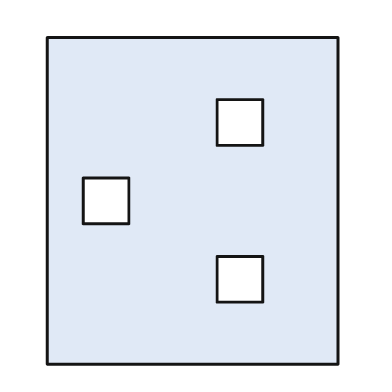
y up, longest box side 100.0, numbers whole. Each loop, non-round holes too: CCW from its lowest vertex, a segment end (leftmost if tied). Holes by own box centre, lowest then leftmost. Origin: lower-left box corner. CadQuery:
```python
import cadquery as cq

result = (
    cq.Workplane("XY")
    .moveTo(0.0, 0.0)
    .lineTo(89.0, 0.0)
    .lineTo(89.0, 100.0)
    .lineTo(0.0, 100.0)
    .close()
    .moveTo(52.0, 19.0)
    .lineTo(66.0, 19.0)
    .lineTo(66.0, 33.0)
    .lineTo(52.0, 33.0)
    .close()
    .moveTo(11.0, 43.0)
    .lineTo(25.0, 43.0)
    .lineTo(25.0, 57.0)
    .lineTo(11.0, 57.0)
    .close()
    .moveTo(52.0, 67.0)
    .lineTo(66.0, 67.0)
    .lineTo(66.0, 81.0)
    .lineTo(52.0, 81.0)
    .close()
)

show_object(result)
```